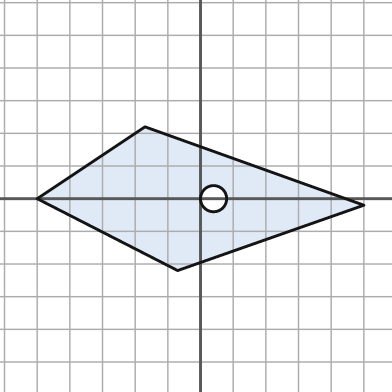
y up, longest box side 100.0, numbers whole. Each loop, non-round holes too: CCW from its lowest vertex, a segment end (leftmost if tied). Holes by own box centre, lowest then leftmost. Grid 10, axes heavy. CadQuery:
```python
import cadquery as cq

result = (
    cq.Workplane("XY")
    .moveTo(-7.0, -22.0)
    .lineTo(50.0, -2.0)
    .lineTo(-17.0, 22.0)
    .lineTo(-50.0, 0.0)
    .close()
    .moveTo(4.0, 0.0)
    .circle(4.0)
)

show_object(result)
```